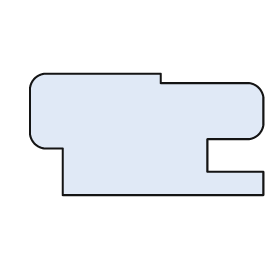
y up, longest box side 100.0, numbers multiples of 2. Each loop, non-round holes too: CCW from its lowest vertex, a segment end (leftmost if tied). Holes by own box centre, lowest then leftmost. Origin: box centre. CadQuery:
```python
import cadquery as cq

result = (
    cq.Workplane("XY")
    .moveTo(-36.0, -26.0)
    .lineTo(50.0, -26.0)
    .lineTo(50.0, -16.0)
    .lineTo(26.0, -16.0)
    .lineTo(26.0, -2.0)
    .lineTo(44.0, -2.0)
    .threePointArc((48.0, 0.0), (50.0, 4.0))
    .lineTo(50.0, 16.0)
    .threePointArc((48.0, 20.0), (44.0, 22.0))
    .lineTo(6.0, 22.0)
    .lineTo(6.0, 26.0)
    .lineTo(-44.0, 26.0)
    .threePointArc((-48.0, 24.0), (-50.0, 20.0))
    .lineTo(-50.0, 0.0)
    .threePointArc((-48.0, -4.0), (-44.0, -6.0))
    .lineTo(-36.0, -6.0)
    .close()
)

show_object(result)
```